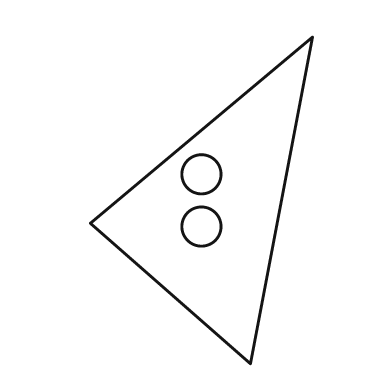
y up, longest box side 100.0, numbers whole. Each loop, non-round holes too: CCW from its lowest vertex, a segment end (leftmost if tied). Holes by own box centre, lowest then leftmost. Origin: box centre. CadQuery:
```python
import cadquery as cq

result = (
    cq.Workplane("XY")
    .moveTo(15.0, -50.0)
    .lineTo(34.0, 50.0)
    .lineTo(-34.0, -7.0)
    .close()
    .moveTo(0.0, -8.0)
    .circle(6.0)
    .moveTo(0.0, 8.0)
    .circle(6.0)
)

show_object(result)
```